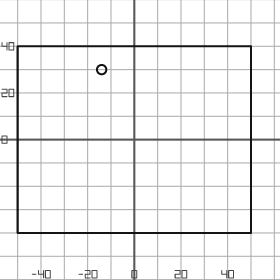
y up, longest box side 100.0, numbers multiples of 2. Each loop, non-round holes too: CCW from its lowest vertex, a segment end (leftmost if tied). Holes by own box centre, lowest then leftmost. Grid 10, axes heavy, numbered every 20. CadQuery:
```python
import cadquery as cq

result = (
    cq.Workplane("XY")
    .moveTo(-50.0, -40.0)
    .lineTo(50.0, -40.0)
    .lineTo(50.0, 40.0)
    .lineTo(-50.0, 40.0)
    .close()
    .moveTo(-14.0, 30.0)
    .circle(2.0)
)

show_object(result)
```